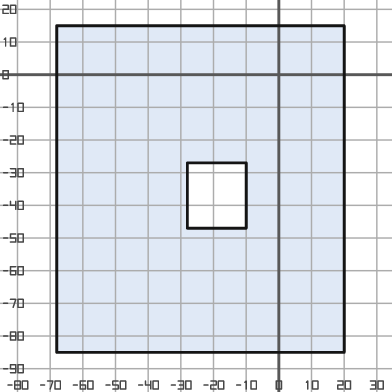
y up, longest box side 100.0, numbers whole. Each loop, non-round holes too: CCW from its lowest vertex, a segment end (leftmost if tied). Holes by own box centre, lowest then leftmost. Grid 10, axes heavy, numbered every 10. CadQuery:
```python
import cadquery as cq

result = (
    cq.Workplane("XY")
    .moveTo(-68.0, -85.0)
    .lineTo(20.0, -85.0)
    .lineTo(20.0, 15.0)
    .lineTo(-68.0, 15.0)
    .close()
    .moveTo(-28.0, -47.0)
    .lineTo(-10.0, -47.0)
    .lineTo(-10.0, -27.0)
    .lineTo(-28.0, -27.0)
    .close()
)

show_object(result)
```